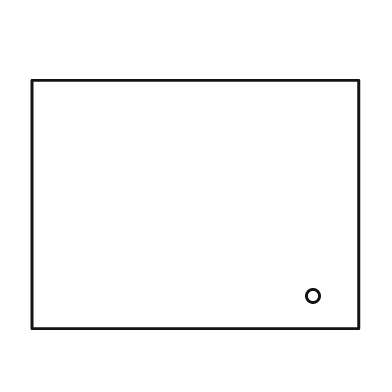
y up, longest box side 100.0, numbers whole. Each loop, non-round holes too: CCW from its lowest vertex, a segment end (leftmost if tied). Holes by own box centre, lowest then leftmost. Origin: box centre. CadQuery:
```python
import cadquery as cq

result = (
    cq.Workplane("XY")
    .moveTo(-50.0, -38.0)
    .lineTo(50.0, -38.0)
    .lineTo(50.0, 38.0)
    .lineTo(-50.0, 38.0)
    .close()
    .moveTo(36.0, -28.0)
    .circle(2.0)
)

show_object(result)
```